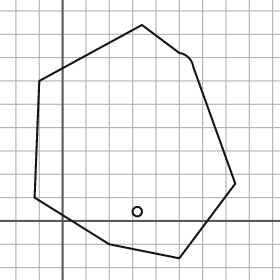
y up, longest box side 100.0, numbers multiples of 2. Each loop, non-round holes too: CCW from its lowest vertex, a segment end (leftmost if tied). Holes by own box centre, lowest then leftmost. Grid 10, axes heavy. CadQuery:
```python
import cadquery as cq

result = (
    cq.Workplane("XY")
    .moveTo(50.0, -16.0)
    .lineTo(74.0, 16.0)
    .lineTo(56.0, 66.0)
    .threePointArc((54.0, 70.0), (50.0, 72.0))
    .lineTo(34.0, 84.0)
    .lineTo(-10.0, 60.0)
    .lineTo(-12.0, 10.0)
    .lineTo(20.0, -10.0)
    .close()
    .moveTo(32.0, 4.0)
    .circle(2.0)
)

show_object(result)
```